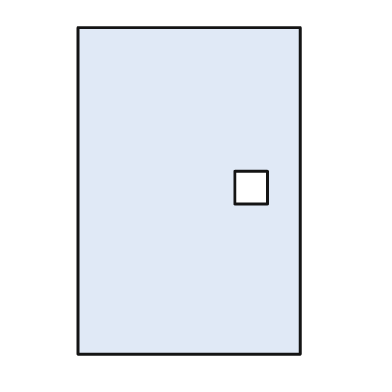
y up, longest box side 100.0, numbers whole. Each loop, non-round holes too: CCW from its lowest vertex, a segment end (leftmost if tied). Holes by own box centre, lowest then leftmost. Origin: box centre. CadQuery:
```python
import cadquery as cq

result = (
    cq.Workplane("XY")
    .moveTo(-34.0, -50.0)
    .lineTo(34.0, -50.0)
    .lineTo(34.0, 50.0)
    .lineTo(-34.0, 50.0)
    .close()
    .moveTo(14.0, -4.0)
    .lineTo(24.0, -4.0)
    .lineTo(24.0, 6.0)
    .lineTo(14.0, 6.0)
    .close()
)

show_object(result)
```